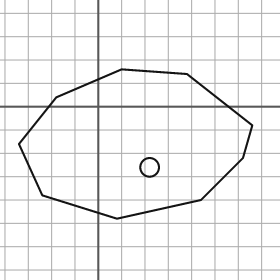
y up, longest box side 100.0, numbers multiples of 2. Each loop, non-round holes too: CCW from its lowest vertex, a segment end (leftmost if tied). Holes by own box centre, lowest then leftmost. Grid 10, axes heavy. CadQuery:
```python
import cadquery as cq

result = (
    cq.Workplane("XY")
    .moveTo(8.0, -48.0)
    .lineTo(44.0, -40.0)
    .lineTo(62.0, -22.0)
    .lineTo(66.0, -8.0)
    .lineTo(38.0, 14.0)
    .lineTo(10.0, 16.0)
    .lineTo(-18.0, 4.0)
    .lineTo(-34.0, -16.0)
    .lineTo(-24.0, -38.0)
    .close()
    .moveTo(22.0, -26.0)
    .circle(4.0)
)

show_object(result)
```